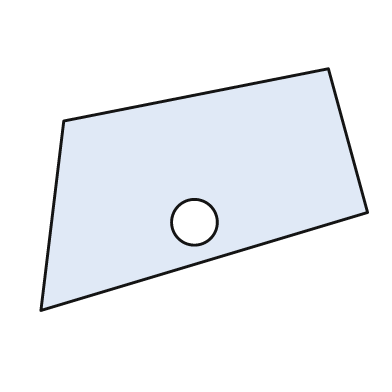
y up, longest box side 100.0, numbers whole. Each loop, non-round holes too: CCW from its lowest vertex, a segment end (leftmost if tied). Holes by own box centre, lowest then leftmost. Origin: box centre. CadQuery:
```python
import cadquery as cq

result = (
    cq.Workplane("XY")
    .moveTo(-50.0, -37.0)
    .lineTo(50.0, -7.0)
    .lineTo(38.0, 37.0)
    .lineTo(-43.0, 21.0)
    .close()
    .moveTo(-3.0, -10.0)
    .circle(7.0)
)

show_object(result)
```